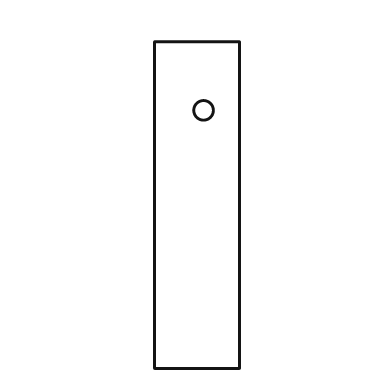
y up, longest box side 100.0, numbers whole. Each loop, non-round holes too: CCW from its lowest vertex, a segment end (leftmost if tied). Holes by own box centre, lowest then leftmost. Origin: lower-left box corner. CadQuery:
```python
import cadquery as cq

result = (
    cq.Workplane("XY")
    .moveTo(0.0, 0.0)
    .lineTo(26.0, 0.0)
    .lineTo(26.0, 100.0)
    .lineTo(0.0, 100.0)
    .close()
    .moveTo(15.0, 79.0)
    .circle(3.0)
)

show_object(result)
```